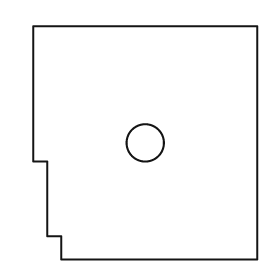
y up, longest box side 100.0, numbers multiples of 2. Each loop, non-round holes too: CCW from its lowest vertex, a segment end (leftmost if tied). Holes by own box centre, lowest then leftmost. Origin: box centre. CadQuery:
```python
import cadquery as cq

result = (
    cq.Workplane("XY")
    .moveTo(-36.0, -50.0)
    .lineTo(48.0, -50.0)
    .lineTo(48.0, 50.0)
    .lineTo(-48.0, 50.0)
    .lineTo(-48.0, -8.0)
    .lineTo(-42.0, -8.0)
    .lineTo(-42.0, -40.0)
    .lineTo(-36.0, -40.0)
    .close()
    .moveTo(0.0, 0.0)
    .circle(8.0)
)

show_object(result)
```